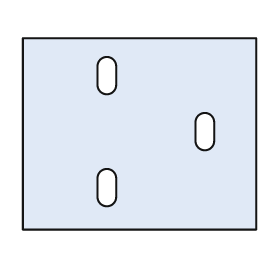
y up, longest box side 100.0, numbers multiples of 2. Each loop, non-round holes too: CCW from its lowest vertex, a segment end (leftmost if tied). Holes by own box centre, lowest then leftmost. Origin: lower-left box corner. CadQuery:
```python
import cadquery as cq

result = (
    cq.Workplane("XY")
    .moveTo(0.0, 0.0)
    .lineTo(100.0, 0.0)
    .lineTo(100.0, 82.0)
    .lineTo(0.0, 82.0)
    .close()
    .moveTo(32.0, 14.0)
    .threePointArc((36.0, 10.0), (40.0, 14.0))
    .lineTo(40.0, 22.0)
    .threePointArc((36.0, 26.0), (32.0, 22.0))
    .close()
    .moveTo(74.0, 38.0)
    .threePointArc((78.0, 34.0), (82.0, 38.0))
    .lineTo(82.0, 46.0)
    .threePointArc((78.0, 50.0), (74.0, 46.0))
    .close()
    .moveTo(32.0, 62.0)
    .threePointArc((36.0, 58.0), (40.0, 62.0))
    .lineTo(40.0, 70.0)
    .threePointArc((36.0, 74.0), (32.0, 70.0))
    .close()
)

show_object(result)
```